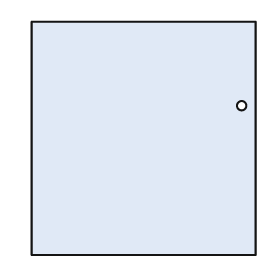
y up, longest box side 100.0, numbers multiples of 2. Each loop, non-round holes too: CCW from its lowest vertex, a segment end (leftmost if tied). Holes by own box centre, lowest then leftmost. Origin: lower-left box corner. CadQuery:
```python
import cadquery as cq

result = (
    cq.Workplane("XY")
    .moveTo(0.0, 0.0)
    .lineTo(96.0, 0.0)
    .lineTo(96.0, 100.0)
    .lineTo(0.0, 100.0)
    .close()
    .moveTo(90.0, 64.0)
    .circle(2.0)
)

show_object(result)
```